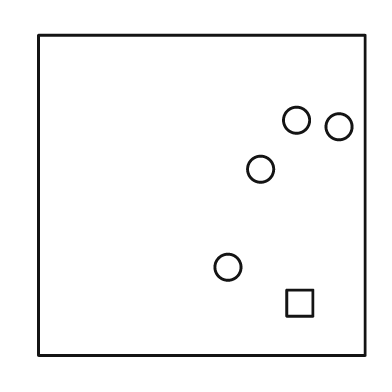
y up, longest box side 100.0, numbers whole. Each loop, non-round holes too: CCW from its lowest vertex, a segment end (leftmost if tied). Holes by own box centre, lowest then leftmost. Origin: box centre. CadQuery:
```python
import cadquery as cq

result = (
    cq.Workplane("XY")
    .moveTo(-50.0, -49.0)
    .lineTo(50.0, -49.0)
    .lineTo(50.0, 49.0)
    .lineTo(-50.0, 49.0)
    .close()
    .moveTo(26.0, -37.0)
    .lineTo(34.0, -37.0)
    .lineTo(34.0, -29.0)
    .lineTo(26.0, -29.0)
    .close()
    .moveTo(8.0, -22.0)
    .circle(4.0)
    .moveTo(18.0, 8.0)
    .circle(4.0)
    .moveTo(42.0, 21.0)
    .circle(4.0)
    .moveTo(29.0, 23.0)
    .circle(4.0)
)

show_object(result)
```